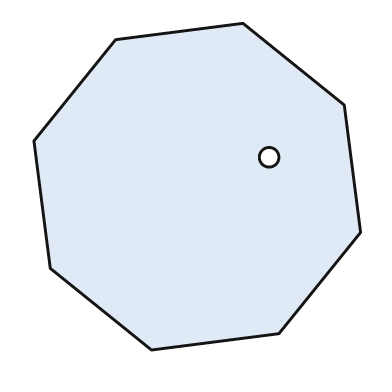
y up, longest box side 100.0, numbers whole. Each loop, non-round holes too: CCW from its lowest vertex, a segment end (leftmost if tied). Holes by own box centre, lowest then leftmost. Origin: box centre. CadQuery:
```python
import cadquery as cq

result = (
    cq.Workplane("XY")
    .moveTo(-14.0, -50.0)
    .lineTo(25.0, -45.0)
    .lineTo(50.0, -14.0)
    .lineTo(45.0, 25.0)
    .lineTo(14.0, 50.0)
    .lineTo(-25.0, 45.0)
    .lineTo(-50.0, 14.0)
    .lineTo(-45.0, -25.0)
    .close()
    .moveTo(22.0, 9.0)
    .circle(3.0)
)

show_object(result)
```